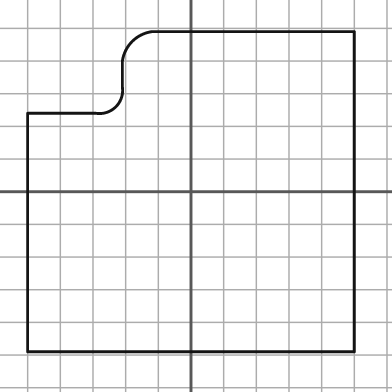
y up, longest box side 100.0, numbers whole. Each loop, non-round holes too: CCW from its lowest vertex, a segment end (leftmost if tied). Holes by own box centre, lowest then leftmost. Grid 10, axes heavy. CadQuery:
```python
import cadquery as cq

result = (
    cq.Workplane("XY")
    .moveTo(-50.0, -49.0)
    .lineTo(50.0, -49.0)
    .lineTo(50.0, 49.0)
    .lineTo(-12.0, 49.0)
    .threePointArc((-18.0, 46.0), (-21.0, 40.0))
    .lineTo(-21.0, 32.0)
    .threePointArc((-23.0, 26.0), (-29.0, 24.0))
    .lineTo(-50.0, 24.0)
    .close()
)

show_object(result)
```